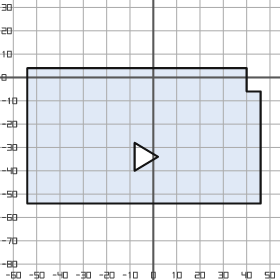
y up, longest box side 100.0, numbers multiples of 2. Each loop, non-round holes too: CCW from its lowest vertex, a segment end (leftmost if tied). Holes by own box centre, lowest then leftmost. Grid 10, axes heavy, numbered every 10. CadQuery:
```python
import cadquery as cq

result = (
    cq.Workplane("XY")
    .moveTo(-54.0, -54.0)
    .lineTo(46.0, -54.0)
    .lineTo(46.0, -6.0)
    .lineTo(40.0, -6.0)
    .lineTo(40.0, 4.0)
    .lineTo(-54.0, 4.0)
    .close()
    .moveTo(-8.0, -40.0)
    .lineTo(2.0, -34.0)
    .lineTo(-8.0, -28.0)
    .close()
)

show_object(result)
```